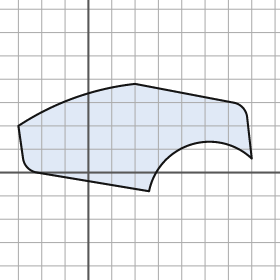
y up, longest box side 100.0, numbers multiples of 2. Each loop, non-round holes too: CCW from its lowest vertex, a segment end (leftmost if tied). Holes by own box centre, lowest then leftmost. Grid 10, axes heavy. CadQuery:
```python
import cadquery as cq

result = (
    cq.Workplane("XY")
    .moveTo(26.0, -8.0)
    .threePointArc((44.0, 12.0), (70.0, 6.0))
    .lineTo(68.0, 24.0)
    .threePointArc((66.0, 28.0), (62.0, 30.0))
    .lineTo(20.0, 38.0)
    .threePointArc((-6.0, 32.0), (-30.0, 20.0))
    .lineTo(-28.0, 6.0)
    .threePointArc((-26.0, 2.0), (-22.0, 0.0))
    .close()
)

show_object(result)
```